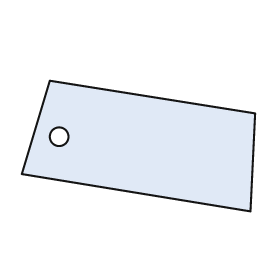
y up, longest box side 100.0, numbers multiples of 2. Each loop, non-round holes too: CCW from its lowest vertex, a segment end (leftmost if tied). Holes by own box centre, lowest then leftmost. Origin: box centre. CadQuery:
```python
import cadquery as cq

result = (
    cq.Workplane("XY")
    .moveTo(48.0, -28.0)
    .lineTo(50.0, 14.0)
    .lineTo(-38.0, 28.0)
    .lineTo(-50.0, -12.0)
    .close()
    .moveTo(-34.0, 4.0)
    .circle(4.0)
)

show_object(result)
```